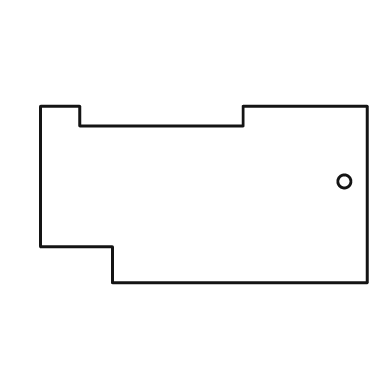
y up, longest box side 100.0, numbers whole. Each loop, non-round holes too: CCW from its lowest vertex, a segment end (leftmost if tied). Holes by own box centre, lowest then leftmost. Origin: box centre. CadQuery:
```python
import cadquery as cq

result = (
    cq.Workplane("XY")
    .moveTo(-28.0, -27.0)
    .lineTo(50.0, -27.0)
    .lineTo(50.0, 27.0)
    .lineTo(12.0, 27.0)
    .lineTo(12.0, 21.0)
    .lineTo(-38.0, 21.0)
    .lineTo(-38.0, 27.0)
    .lineTo(-50.0, 27.0)
    .lineTo(-50.0, -16.0)
    .lineTo(-28.0, -16.0)
    .close()
    .moveTo(43.0, 4.0)
    .circle(2.0)
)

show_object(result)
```